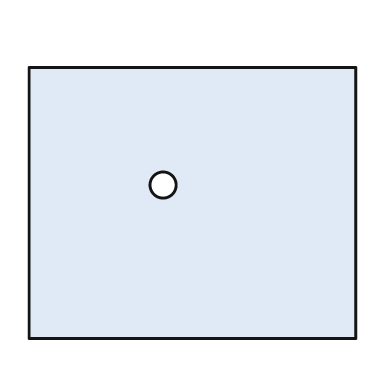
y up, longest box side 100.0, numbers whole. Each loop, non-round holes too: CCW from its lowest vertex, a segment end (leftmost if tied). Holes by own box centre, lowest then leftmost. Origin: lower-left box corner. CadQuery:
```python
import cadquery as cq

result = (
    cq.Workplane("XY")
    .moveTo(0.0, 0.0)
    .lineTo(100.0, 0.0)
    .lineTo(100.0, 83.0)
    .lineTo(0.0, 83.0)
    .close()
    .moveTo(41.0, 47.0)
    .circle(4.0)
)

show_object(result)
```